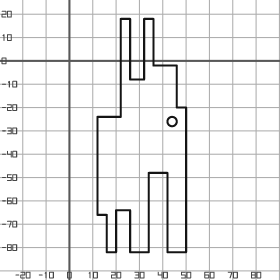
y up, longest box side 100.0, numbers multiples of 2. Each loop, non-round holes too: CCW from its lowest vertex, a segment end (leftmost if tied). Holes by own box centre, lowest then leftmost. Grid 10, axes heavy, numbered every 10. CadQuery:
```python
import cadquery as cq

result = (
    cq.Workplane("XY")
    .moveTo(16.0, -82.0)
    .lineTo(20.0, -82.0)
    .lineTo(20.0, -64.0)
    .lineTo(26.0, -64.0)
    .lineTo(26.0, -82.0)
    .lineTo(34.0, -82.0)
    .lineTo(34.0, -48.0)
    .lineTo(42.0, -48.0)
    .lineTo(42.0, -82.0)
    .lineTo(50.0, -82.0)
    .lineTo(50.0, -20.0)
    .lineTo(46.0, -20.0)
    .lineTo(46.0, -2.0)
    .lineTo(36.0, -2.0)
    .lineTo(36.0, 18.0)
    .lineTo(32.0, 18.0)
    .lineTo(32.0, -8.0)
    .lineTo(26.0, -8.0)
    .lineTo(26.0, 18.0)
    .lineTo(22.0, 18.0)
    .lineTo(22.0, -24.0)
    .lineTo(12.0, -24.0)
    .lineTo(12.0, -66.0)
    .lineTo(16.0, -66.0)
    .close()
    .moveTo(44.0, -26.0)
    .circle(2.0)
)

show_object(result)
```